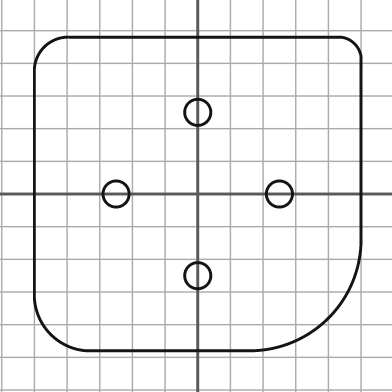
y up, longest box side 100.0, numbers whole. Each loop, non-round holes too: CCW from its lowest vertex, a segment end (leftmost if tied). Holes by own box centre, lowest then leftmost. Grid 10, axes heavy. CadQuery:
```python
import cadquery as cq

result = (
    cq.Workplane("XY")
    .moveTo(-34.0, -48.0)
    .lineTo(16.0, -48.0)
    .threePointArc((40.0, -38.0), (50.0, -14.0))
    .lineTo(50.0, 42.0)
    .threePointArc((48.0, 46.0), (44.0, 48.0))
    .lineTo(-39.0, 48.0)
    .threePointArc((-47.0, 45.0), (-50.0, 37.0))
    .lineTo(-50.0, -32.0)
    .threePointArc((-45.0, -43.0), (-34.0, -48.0))
    .close()
    .moveTo(0.0, -25.0)
    .circle(4.0)
    .moveTo(-25.0, 0.0)
    .circle(4.0)
    .moveTo(25.0, 0.0)
    .circle(4.0)
    .moveTo(0.0, 25.0)
    .circle(4.0)
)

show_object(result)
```